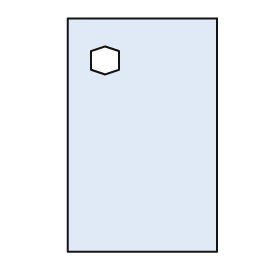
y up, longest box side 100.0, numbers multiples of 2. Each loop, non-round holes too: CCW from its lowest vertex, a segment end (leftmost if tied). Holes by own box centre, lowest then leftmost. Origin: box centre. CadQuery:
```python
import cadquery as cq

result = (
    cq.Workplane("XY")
    .moveTo(-32.0, -50.0)
    .lineTo(32.0, -50.0)
    .lineTo(32.0, 50.0)
    .lineTo(-32.0, 50.0)
    .close()
    .moveTo(-16.0, 26.0)
    .lineTo(-10.0, 28.0)
    .lineTo(-10.0, 36.0)
    .lineTo(-16.0, 38.0)
    .lineTo(-22.0, 36.0)
    .lineTo(-22.0, 28.0)
    .close()
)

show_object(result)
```